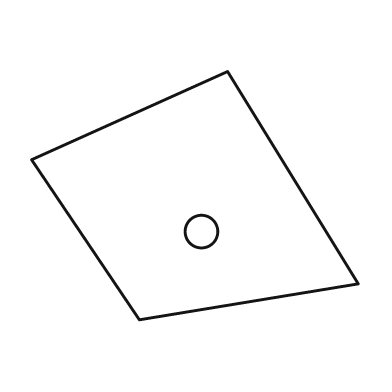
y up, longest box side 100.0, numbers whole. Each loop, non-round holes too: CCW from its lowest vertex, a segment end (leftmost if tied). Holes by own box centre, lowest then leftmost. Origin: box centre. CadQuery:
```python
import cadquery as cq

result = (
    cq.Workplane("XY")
    .moveTo(-17.0, -38.0)
    .lineTo(50.0, -27.0)
    .lineTo(10.0, 38.0)
    .lineTo(-50.0, 11.0)
    .close()
    .moveTo(2.0, -11.0)
    .circle(5.0)
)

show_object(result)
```